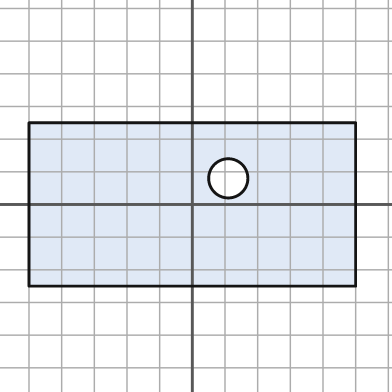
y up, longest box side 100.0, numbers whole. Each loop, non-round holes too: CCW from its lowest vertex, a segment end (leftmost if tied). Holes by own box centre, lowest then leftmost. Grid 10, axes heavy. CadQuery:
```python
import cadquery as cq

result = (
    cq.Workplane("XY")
    .moveTo(-50.0, -25.0)
    .lineTo(50.0, -25.0)
    .lineTo(50.0, 25.0)
    .lineTo(-50.0, 25.0)
    .close()
    .moveTo(11.0, 8.0)
    .circle(6.0)
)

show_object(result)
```